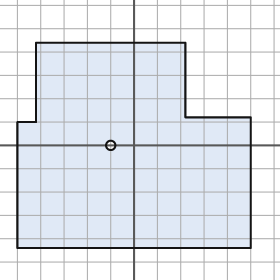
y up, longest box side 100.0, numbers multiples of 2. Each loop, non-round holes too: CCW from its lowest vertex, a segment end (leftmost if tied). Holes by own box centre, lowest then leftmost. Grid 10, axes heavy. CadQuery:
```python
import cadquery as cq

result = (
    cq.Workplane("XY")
    .moveTo(-50.0, -44.0)
    .lineTo(50.0, -44.0)
    .lineTo(50.0, 12.0)
    .lineTo(22.0, 12.0)
    .lineTo(22.0, 44.0)
    .lineTo(-42.0, 44.0)
    .lineTo(-42.0, 10.0)
    .lineTo(-50.0, 10.0)
    .close()
    .moveTo(-10.0, 0.0)
    .circle(2.0)
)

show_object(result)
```